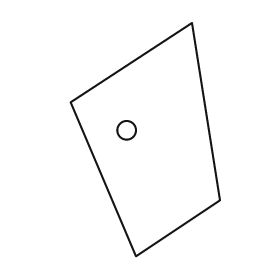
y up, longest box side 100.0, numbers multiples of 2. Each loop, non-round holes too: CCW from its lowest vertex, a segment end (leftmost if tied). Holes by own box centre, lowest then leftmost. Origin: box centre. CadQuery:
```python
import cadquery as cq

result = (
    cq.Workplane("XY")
    .moveTo(-4.0, -50.0)
    .lineTo(32.0, -26.0)
    .lineTo(20.0, 50.0)
    .lineTo(-32.0, 16.0)
    .close()
    .moveTo(-8.0, 4.0)
    .circle(4.0)
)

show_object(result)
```